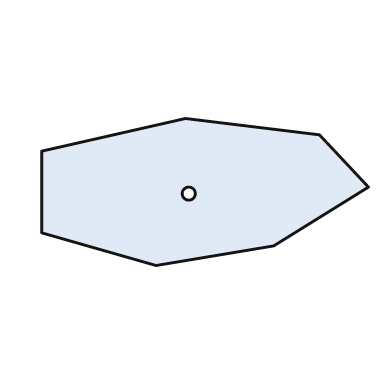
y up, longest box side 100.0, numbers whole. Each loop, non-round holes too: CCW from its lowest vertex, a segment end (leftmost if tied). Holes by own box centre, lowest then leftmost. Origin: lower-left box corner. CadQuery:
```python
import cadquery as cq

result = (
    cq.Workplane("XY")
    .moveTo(35.0, 0.0)
    .lineTo(71.0, 6.0)
    .lineTo(100.0, 24.0)
    .lineTo(85.0, 40.0)
    .lineTo(44.0, 45.0)
    .lineTo(0.0, 35.0)
    .lineTo(0.0, 10.0)
    .close()
    .moveTo(45.0, 22.0)
    .circle(2.0)
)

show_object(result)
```